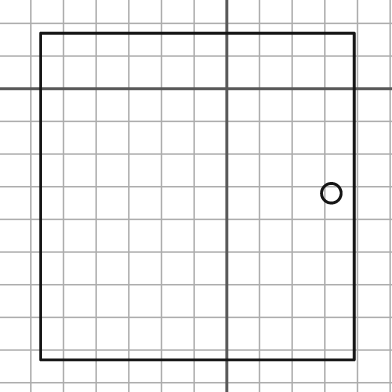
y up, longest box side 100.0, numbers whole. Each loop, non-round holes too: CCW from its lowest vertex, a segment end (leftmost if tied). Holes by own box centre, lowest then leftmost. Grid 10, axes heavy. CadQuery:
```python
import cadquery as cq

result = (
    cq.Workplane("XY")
    .moveTo(-57.0, -83.0)
    .lineTo(39.0, -83.0)
    .lineTo(39.0, 17.0)
    .lineTo(-57.0, 17.0)
    .close()
    .moveTo(32.0, -32.0)
    .circle(3.0)
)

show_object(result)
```